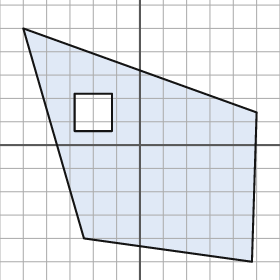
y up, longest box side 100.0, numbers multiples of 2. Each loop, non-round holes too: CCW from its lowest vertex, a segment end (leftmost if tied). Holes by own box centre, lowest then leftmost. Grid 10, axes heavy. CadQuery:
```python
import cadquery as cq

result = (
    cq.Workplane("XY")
    .moveTo(48.0, -50.0)
    .lineTo(50.0, 14.0)
    .lineTo(-50.0, 50.0)
    .lineTo(-24.0, -40.0)
    .close()
    .moveTo(-28.0, 6.0)
    .lineTo(-12.0, 6.0)
    .lineTo(-12.0, 22.0)
    .lineTo(-28.0, 22.0)
    .close()
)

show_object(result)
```